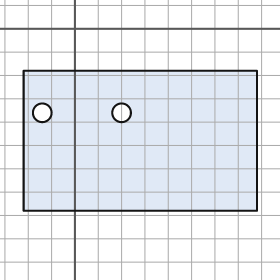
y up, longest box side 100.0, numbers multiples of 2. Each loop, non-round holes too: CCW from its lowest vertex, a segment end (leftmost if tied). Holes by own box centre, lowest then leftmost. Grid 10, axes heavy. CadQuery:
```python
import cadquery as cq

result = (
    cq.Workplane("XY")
    .moveTo(-22.0, -78.0)
    .lineTo(78.0, -78.0)
    .lineTo(78.0, -18.0)
    .lineTo(-22.0, -18.0)
    .close()
    .moveTo(-14.0, -36.0)
    .circle(4.0)
    .moveTo(20.0, -36.0)
    .circle(4.0)
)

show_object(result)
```